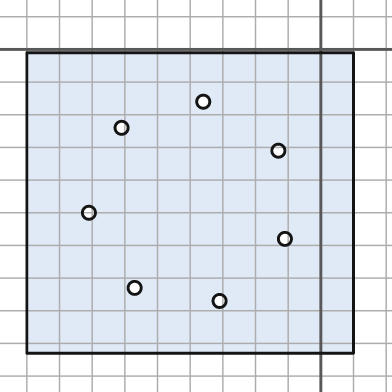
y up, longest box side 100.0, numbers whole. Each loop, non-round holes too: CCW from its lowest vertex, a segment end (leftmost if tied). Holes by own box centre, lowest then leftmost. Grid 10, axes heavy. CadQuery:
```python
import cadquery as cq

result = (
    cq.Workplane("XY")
    .moveTo(-90.0, -93.0)
    .lineTo(10.0, -93.0)
    .lineTo(10.0, -1.0)
    .lineTo(-90.0, -1.0)
    .close()
    .moveTo(-31.0, -77.0)
    .circle(2.0)
    .moveTo(-57.0, -73.0)
    .circle(2.0)
    .moveTo(-11.0, -58.0)
    .circle(2.0)
    .moveTo(-71.0, -50.0)
    .circle(2.0)
    .moveTo(-13.0, -31.0)
    .circle(2.0)
    .moveTo(-61.0, -24.0)
    .circle(2.0)
    .moveTo(-36.0, -16.0)
    .circle(2.0)
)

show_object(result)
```